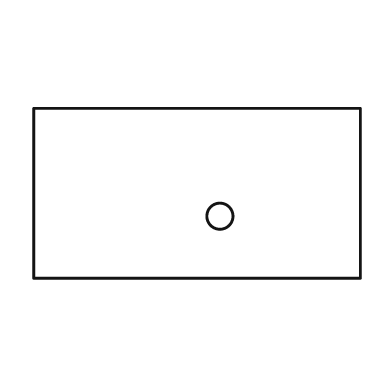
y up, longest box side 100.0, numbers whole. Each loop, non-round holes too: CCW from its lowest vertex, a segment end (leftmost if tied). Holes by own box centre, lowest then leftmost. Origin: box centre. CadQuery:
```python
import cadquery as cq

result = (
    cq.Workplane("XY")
    .moveTo(-50.0, -26.0)
    .lineTo(50.0, -26.0)
    .lineTo(50.0, 26.0)
    .lineTo(-50.0, 26.0)
    .close()
    .moveTo(7.0, -7.0)
    .circle(4.0)
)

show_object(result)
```